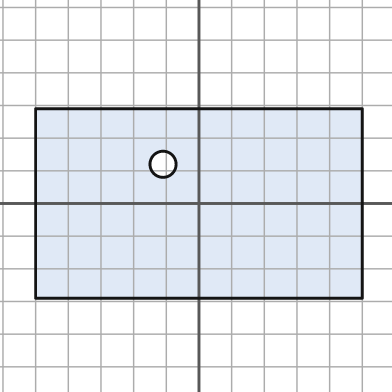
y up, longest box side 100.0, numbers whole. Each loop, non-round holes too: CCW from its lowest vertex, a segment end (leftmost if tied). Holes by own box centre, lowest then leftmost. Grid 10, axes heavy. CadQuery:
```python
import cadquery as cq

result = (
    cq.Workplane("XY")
    .moveTo(-50.0, -29.0)
    .lineTo(50.0, -29.0)
    .lineTo(50.0, 29.0)
    .lineTo(-50.0, 29.0)
    .close()
    .moveTo(-11.0, 12.0)
    .circle(4.0)
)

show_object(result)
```